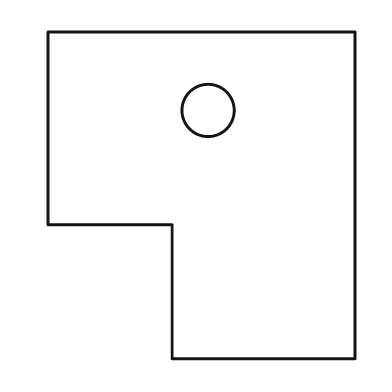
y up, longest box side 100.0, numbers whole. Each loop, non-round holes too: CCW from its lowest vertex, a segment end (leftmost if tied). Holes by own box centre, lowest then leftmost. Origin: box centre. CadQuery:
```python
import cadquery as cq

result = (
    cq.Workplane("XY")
    .moveTo(-9.0, -50.0)
    .lineTo(47.0, -50.0)
    .lineTo(47.0, 50.0)
    .lineTo(-47.0, 50.0)
    .lineTo(-47.0, -9.0)
    .lineTo(-9.0, -9.0)
    .close()
    .moveTo(2.0, 26.0)
    .circle(8.0)
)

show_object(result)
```